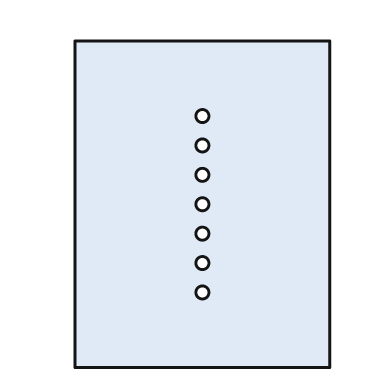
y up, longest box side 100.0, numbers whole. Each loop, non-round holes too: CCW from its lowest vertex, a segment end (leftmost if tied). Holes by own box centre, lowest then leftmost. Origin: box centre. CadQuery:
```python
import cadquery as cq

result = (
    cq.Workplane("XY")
    .moveTo(-39.0, -50.0)
    .lineTo(39.0, -50.0)
    .lineTo(39.0, 50.0)
    .lineTo(-39.0, 50.0)
    .close()
    .moveTo(0.0, -27.0)
    .circle(2.0)
    .moveTo(0.0, -18.0)
    .circle(2.0)
    .moveTo(0.0, -9.0)
    .circle(2.0)
    .moveTo(0.0, 0.0)
    .circle(2.0)
    .moveTo(0.0, 9.0)
    .circle(2.0)
    .moveTo(0.0, 18.0)
    .circle(2.0)
    .moveTo(0.0, 27.0)
    .circle(2.0)
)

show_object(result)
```